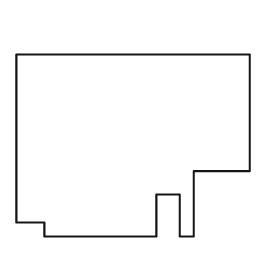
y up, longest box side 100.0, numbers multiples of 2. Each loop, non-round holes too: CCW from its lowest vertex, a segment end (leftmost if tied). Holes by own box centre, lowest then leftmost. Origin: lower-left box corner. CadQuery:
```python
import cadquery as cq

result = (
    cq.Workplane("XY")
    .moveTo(12.0, 0.0)
    .lineTo(60.0, 0.0)
    .lineTo(60.0, 18.0)
    .lineTo(70.0, 18.0)
    .lineTo(70.0, 0.0)
    .lineTo(76.0, 0.0)
    .lineTo(76.0, 28.0)
    .lineTo(100.0, 28.0)
    .lineTo(100.0, 78.0)
    .lineTo(0.0, 78.0)
    .lineTo(0.0, 6.0)
    .lineTo(12.0, 6.0)
    .close()
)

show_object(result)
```